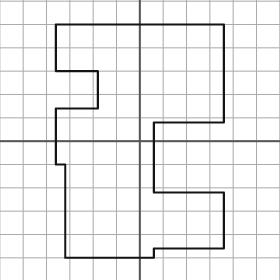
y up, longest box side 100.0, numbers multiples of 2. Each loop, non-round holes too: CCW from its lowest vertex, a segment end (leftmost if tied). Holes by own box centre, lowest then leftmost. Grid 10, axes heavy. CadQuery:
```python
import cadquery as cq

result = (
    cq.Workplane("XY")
    .moveTo(-32.0, -50.0)
    .lineTo(6.0, -50.0)
    .lineTo(6.0, -46.0)
    .lineTo(36.0, -46.0)
    .lineTo(36.0, -22.0)
    .lineTo(6.0, -22.0)
    .lineTo(6.0, 8.0)
    .lineTo(36.0, 8.0)
    .lineTo(36.0, 50.0)
    .lineTo(-36.0, 50.0)
    .lineTo(-36.0, 30.0)
    .lineTo(-18.0, 30.0)
    .lineTo(-18.0, 14.0)
    .lineTo(-36.0, 14.0)
    .lineTo(-36.0, -10.0)
    .lineTo(-32.0, -10.0)
    .close()
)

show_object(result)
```